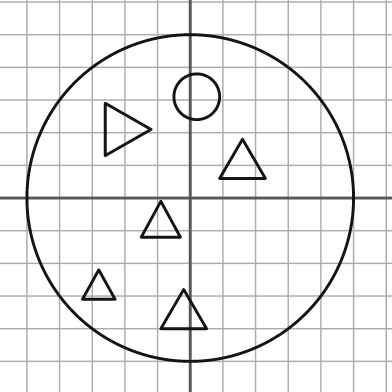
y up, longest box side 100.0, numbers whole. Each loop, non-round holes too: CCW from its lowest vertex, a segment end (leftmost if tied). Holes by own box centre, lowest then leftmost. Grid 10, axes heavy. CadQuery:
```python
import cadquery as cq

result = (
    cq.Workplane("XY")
    .moveTo(0.0, 0.0)
    .circle(50.0)
    .moveTo(-9.0, -40.0)
    .lineTo(5.0, -40.0)
    .lineTo(-2.0, -28.0)
    .close()
    .moveTo(-33.0, -31.0)
    .lineTo(-23.0, -31.0)
    .lineTo(-28.0, -22.0)
    .close()
    .moveTo(-15.0, -12.0)
    .lineTo(-3.0, -12.0)
    .lineTo(-9.0, -1.0)
    .close()
    .moveTo(9.0, 6.0)
    .lineTo(23.0, 6.0)
    .lineTo(16.0, 18.0)
    .close()
    .moveTo(-26.0, 13.0)
    .lineTo(-12.0, 21.0)
    .lineTo(-26.0, 29.0)
    .close()
    .moveTo(2.0, 31.0)
    .circle(7.0)
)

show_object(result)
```